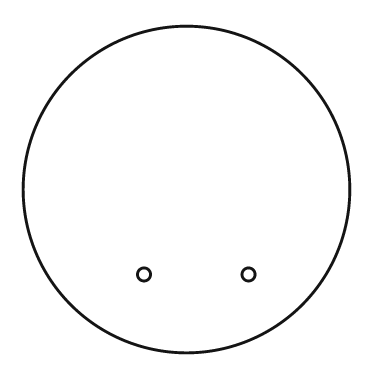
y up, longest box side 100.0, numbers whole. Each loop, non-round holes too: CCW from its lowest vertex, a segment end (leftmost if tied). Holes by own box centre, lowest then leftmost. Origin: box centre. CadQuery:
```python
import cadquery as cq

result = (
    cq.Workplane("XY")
    .moveTo(0.0, 0.0)
    .circle(50.0)
    .moveTo(-13.0, -26.0)
    .circle(2.0)
    .moveTo(19.0, -26.0)
    .circle(2.0)
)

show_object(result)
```